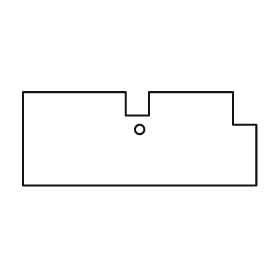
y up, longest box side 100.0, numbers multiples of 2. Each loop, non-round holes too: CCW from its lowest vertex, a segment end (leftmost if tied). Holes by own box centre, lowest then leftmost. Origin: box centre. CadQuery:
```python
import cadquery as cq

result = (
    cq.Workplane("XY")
    .moveTo(-50.0, -20.0)
    .lineTo(50.0, -20.0)
    .lineTo(50.0, 6.0)
    .lineTo(40.0, 6.0)
    .lineTo(40.0, 20.0)
    .lineTo(4.0, 20.0)
    .lineTo(4.0, 10.0)
    .lineTo(-6.0, 10.0)
    .lineTo(-6.0, 20.0)
    .lineTo(-50.0, 20.0)
    .close()
    .moveTo(0.0, 4.0)
    .circle(2.0)
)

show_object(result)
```